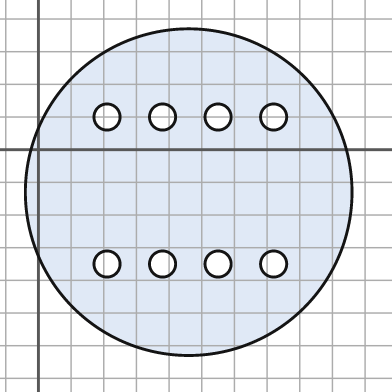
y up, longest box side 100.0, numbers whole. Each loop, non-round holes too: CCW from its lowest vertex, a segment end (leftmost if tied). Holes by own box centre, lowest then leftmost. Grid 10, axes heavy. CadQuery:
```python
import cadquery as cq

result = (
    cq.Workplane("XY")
    .moveTo(46.0, -13.0)
    .circle(50.0)
    .moveTo(21.0, -35.0)
    .circle(4.0)
    .moveTo(38.0, -35.0)
    .circle(4.0)
    .moveTo(55.0, -35.0)
    .circle(4.0)
    .moveTo(72.0, -35.0)
    .circle(4.0)
    .moveTo(21.0, 10.0)
    .circle(4.0)
    .moveTo(38.0, 10.0)
    .circle(4.0)
    .moveTo(55.0, 10.0)
    .circle(4.0)
    .moveTo(72.0, 10.0)
    .circle(4.0)
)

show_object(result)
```